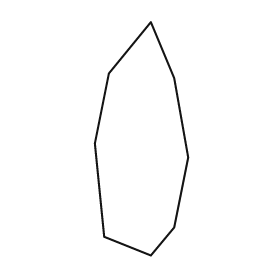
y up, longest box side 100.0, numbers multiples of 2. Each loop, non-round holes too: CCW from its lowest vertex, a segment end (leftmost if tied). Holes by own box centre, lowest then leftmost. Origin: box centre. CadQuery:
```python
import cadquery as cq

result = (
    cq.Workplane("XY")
    .moveTo(4.0, -50.0)
    .lineTo(14.0, -38.0)
    .lineTo(20.0, -8.0)
    .lineTo(14.0, 26.0)
    .lineTo(4.0, 50.0)
    .lineTo(-14.0, 28.0)
    .lineTo(-20.0, -2.0)
    .lineTo(-16.0, -42.0)
    .close()
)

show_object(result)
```